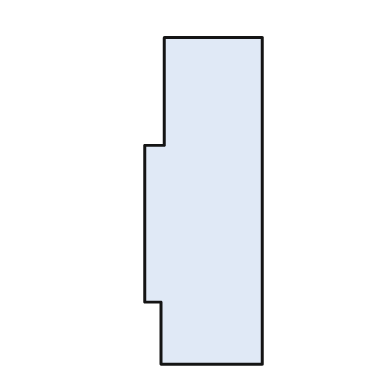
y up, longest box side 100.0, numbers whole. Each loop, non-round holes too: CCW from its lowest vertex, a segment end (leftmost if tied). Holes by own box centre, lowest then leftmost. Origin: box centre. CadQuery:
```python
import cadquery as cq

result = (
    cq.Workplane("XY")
    .moveTo(-13.0, -50.0)
    .lineTo(18.0, -50.0)
    .lineTo(18.0, 50.0)
    .lineTo(-12.0, 50.0)
    .lineTo(-12.0, 17.0)
    .lineTo(-18.0, 17.0)
    .lineTo(-18.0, -31.0)
    .lineTo(-13.0, -31.0)
    .close()
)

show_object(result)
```